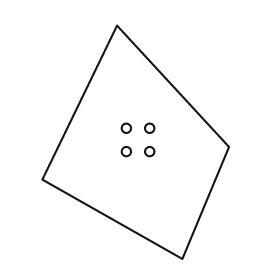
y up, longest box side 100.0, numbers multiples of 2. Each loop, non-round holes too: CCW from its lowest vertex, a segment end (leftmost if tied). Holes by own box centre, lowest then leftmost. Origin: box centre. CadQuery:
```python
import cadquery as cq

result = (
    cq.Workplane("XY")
    .moveTo(20.0, -50.0)
    .lineTo(40.0, -2.0)
    .lineTo(-8.0, 50.0)
    .lineTo(-40.0, -16.0)
    .close()
    .moveTo(-4.0, -4.0)
    .circle(2.0)
    .moveTo(6.0, -4.0)
    .circle(2.0)
    .moveTo(-4.0, 6.0)
    .circle(2.0)
    .moveTo(6.0, 6.0)
    .circle(2.0)
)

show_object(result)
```